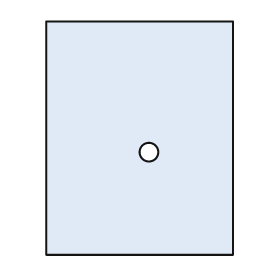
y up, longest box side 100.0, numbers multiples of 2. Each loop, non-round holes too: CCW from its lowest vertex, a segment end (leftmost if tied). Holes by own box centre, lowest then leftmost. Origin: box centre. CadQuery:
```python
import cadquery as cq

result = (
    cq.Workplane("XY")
    .moveTo(-40.0, -50.0)
    .lineTo(40.0, -50.0)
    .lineTo(40.0, 50.0)
    .lineTo(-40.0, 50.0)
    .close()
    .moveTo(4.0, -6.0)
    .circle(4.0)
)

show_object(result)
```